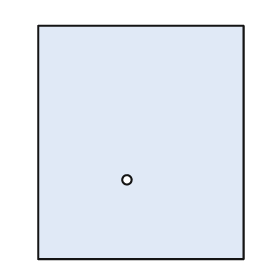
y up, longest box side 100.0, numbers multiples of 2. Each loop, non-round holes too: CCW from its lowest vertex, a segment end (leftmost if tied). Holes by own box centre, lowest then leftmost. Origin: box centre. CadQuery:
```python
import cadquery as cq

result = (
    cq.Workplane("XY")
    .moveTo(-44.0, -50.0)
    .lineTo(44.0, -50.0)
    .lineTo(44.0, 50.0)
    .lineTo(-44.0, 50.0)
    .close()
    .moveTo(-6.0, -16.0)
    .circle(2.0)
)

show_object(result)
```